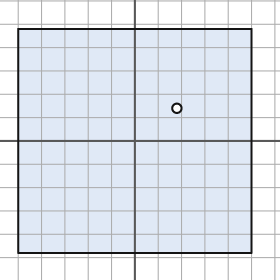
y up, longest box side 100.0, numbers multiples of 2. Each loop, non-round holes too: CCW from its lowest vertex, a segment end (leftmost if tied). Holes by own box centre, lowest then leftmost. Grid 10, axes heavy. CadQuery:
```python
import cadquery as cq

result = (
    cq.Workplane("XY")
    .moveTo(-50.0, -48.0)
    .lineTo(50.0, -48.0)
    .lineTo(50.0, 48.0)
    .lineTo(-50.0, 48.0)
    .close()
    .moveTo(18.0, 14.0)
    .circle(2.0)
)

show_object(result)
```